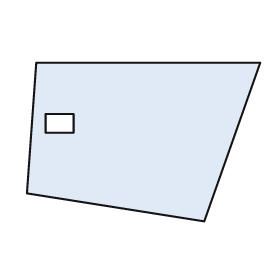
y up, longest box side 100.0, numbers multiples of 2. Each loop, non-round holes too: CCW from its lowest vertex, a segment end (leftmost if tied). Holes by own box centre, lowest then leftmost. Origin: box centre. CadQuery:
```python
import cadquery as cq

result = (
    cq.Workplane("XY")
    .moveTo(26.0, -34.0)
    .lineTo(50.0, 34.0)
    .lineTo(-46.0, 34.0)
    .lineTo(-50.0, -22.0)
    .close()
    .moveTo(-42.0, 4.0)
    .lineTo(-30.0, 4.0)
    .lineTo(-30.0, 12.0)
    .lineTo(-42.0, 12.0)
    .close()
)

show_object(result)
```